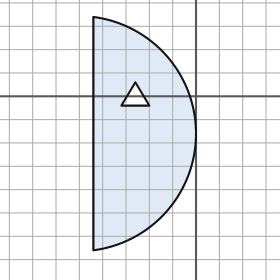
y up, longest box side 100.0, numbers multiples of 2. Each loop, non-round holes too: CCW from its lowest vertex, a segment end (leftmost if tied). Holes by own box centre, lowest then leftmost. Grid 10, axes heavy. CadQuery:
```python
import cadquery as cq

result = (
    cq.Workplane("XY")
    .moveTo(-44.0, -66.0)
    .threePointArc((0.0, -16.0), (-44.0, 34.0))
    .close()
    .moveTo(-32.0, -4.0)
    .lineTo(-20.0, -4.0)
    .lineTo(-26.0, 6.0)
    .close()
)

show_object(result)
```